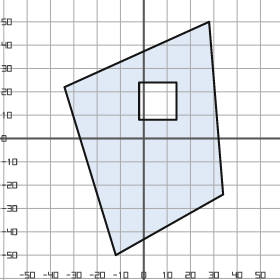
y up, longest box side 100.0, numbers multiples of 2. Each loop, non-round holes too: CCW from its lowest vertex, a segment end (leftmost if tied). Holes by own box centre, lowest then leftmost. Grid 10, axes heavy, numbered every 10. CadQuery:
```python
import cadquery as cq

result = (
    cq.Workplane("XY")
    .moveTo(-12.0, -50.0)
    .lineTo(34.0, -24.0)
    .lineTo(28.0, 50.0)
    .lineTo(-34.0, 22.0)
    .close()
    .moveTo(-2.0, 8.0)
    .lineTo(14.0, 8.0)
    .lineTo(14.0, 24.0)
    .lineTo(-2.0, 24.0)
    .close()
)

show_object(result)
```